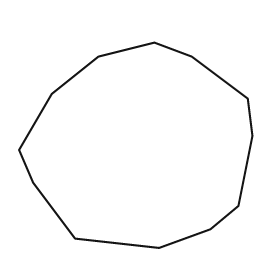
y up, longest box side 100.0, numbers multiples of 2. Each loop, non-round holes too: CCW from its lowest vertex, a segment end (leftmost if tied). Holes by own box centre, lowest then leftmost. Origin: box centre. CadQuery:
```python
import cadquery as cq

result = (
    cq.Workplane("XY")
    .moveTo(10.0, -44.0)
    .lineTo(32.0, -36.0)
    .lineTo(44.0, -26.0)
    .lineTo(50.0, 4.0)
    .lineTo(48.0, 20.0)
    .lineTo(24.0, 38.0)
    .lineTo(8.0, 44.0)
    .lineTo(-16.0, 38.0)
    .lineTo(-36.0, 22.0)
    .lineTo(-50.0, -2.0)
    .lineTo(-44.0, -16.0)
    .lineTo(-26.0, -40.0)
    .close()
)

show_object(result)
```